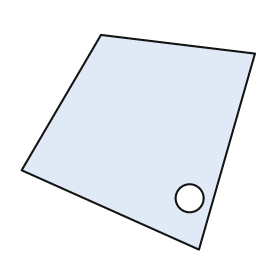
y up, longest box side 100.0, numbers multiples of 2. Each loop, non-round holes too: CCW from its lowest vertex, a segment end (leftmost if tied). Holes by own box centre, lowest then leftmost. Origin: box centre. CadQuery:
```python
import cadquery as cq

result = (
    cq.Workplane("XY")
    .moveTo(26.0, -46.0)
    .lineTo(50.0, 38.0)
    .lineTo(-16.0, 46.0)
    .lineTo(-50.0, -12.0)
    .close()
    .moveTo(22.0, -24.0)
    .circle(6.0)
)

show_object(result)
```